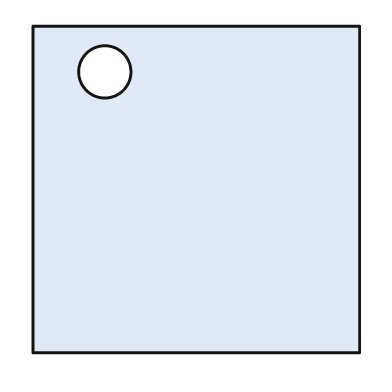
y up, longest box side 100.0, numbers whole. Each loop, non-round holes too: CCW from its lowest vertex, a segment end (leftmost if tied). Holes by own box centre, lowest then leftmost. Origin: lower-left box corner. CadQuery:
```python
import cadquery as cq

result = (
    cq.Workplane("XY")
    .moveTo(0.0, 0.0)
    .lineTo(100.0, 0.0)
    .lineTo(100.0, 100.0)
    .lineTo(0.0, 100.0)
    .close()
    .moveTo(22.0, 86.0)
    .circle(8.0)
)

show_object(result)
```